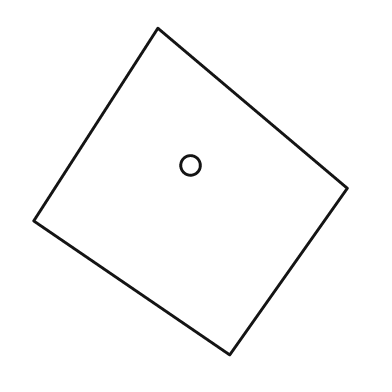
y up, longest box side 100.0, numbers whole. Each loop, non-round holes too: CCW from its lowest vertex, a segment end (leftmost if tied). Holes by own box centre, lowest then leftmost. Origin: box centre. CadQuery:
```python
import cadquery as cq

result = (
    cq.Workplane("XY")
    .moveTo(12.0, -50.0)
    .lineTo(48.0, 1.0)
    .lineTo(-10.0, 50.0)
    .lineTo(-48.0, -9.0)
    .close()
    .moveTo(0.0, 8.0)
    .circle(3.0)
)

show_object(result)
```